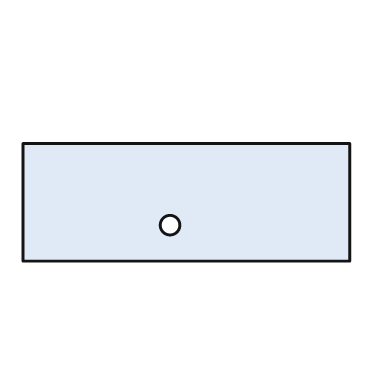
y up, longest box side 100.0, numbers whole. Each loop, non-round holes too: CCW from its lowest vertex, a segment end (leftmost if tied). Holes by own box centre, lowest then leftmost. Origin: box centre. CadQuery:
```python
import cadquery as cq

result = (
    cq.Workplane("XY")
    .moveTo(-50.0, -18.0)
    .lineTo(50.0, -18.0)
    .lineTo(50.0, 18.0)
    .lineTo(-50.0, 18.0)
    .close()
    .moveTo(-5.0, -7.0)
    .circle(3.0)
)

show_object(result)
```